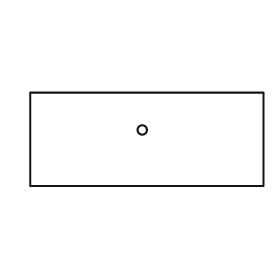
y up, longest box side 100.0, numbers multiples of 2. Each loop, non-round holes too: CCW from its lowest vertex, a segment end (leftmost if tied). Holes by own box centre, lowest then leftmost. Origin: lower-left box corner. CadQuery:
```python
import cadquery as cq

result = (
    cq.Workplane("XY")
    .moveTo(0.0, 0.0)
    .lineTo(100.0, 0.0)
    .lineTo(100.0, 40.0)
    .lineTo(0.0, 40.0)
    .close()
    .moveTo(48.0, 24.0)
    .circle(2.0)
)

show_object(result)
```